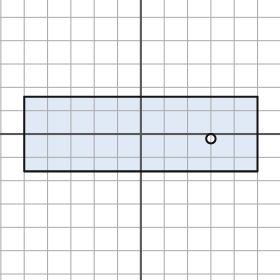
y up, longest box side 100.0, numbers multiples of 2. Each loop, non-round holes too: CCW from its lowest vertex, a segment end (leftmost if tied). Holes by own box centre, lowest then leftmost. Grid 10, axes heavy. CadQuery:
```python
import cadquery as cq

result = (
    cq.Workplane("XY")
    .moveTo(-50.0, -16.0)
    .lineTo(50.0, -16.0)
    .lineTo(50.0, 16.0)
    .lineTo(-50.0, 16.0)
    .close()
    .moveTo(30.0, -2.0)
    .circle(2.0)
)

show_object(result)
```